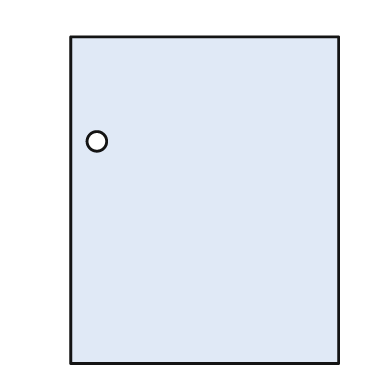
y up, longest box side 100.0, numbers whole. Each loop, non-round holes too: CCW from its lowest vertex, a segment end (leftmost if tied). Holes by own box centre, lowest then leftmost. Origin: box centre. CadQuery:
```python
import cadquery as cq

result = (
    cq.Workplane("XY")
    .moveTo(-41.0, -50.0)
    .lineTo(41.0, -50.0)
    .lineTo(41.0, 50.0)
    .lineTo(-41.0, 50.0)
    .close()
    .moveTo(-33.0, 18.0)
    .circle(3.0)
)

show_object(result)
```